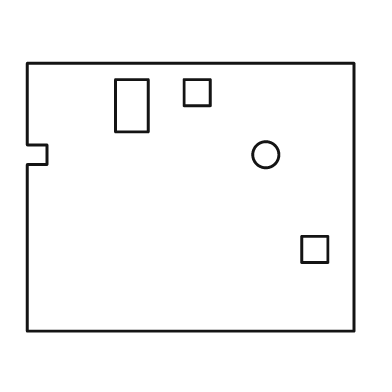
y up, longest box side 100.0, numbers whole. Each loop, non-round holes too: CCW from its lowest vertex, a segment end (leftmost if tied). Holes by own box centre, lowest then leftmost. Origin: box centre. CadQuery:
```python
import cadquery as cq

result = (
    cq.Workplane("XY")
    .moveTo(-50.0, -41.0)
    .lineTo(50.0, -41.0)
    .lineTo(50.0, 41.0)
    .lineTo(-50.0, 41.0)
    .lineTo(-50.0, 16.0)
    .lineTo(-44.0, 16.0)
    .lineTo(-44.0, 10.0)
    .lineTo(-50.0, 10.0)
    .close()
    .moveTo(34.0, -20.0)
    .lineTo(42.0, -20.0)
    .lineTo(42.0, -12.0)
    .lineTo(34.0, -12.0)
    .close()
    .moveTo(23.0, 13.0)
    .circle(4.0)
    .moveTo(-23.0, 20.0)
    .lineTo(-13.0, 20.0)
    .lineTo(-13.0, 36.0)
    .lineTo(-23.0, 36.0)
    .close()
    .moveTo(-2.0, 28.0)
    .lineTo(6.0, 28.0)
    .lineTo(6.0, 36.0)
    .lineTo(-2.0, 36.0)
    .close()
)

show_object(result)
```